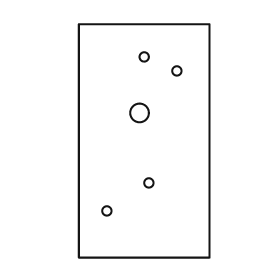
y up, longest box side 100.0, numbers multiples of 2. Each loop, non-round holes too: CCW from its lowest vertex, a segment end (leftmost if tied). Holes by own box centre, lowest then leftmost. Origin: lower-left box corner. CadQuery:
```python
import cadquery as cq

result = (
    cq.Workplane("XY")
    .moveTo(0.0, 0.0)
    .lineTo(56.0, 0.0)
    .lineTo(56.0, 100.0)
    .lineTo(0.0, 100.0)
    .close()
    .moveTo(12.0, 20.0)
    .circle(2.0)
    .moveTo(30.0, 32.0)
    .circle(2.0)
    .moveTo(26.0, 62.0)
    .circle(4.0)
    .moveTo(42.0, 80.0)
    .circle(2.0)
    .moveTo(28.0, 86.0)
    .circle(2.0)
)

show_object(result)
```